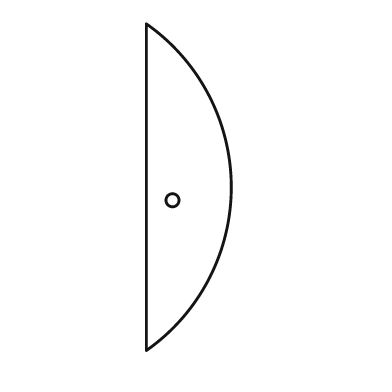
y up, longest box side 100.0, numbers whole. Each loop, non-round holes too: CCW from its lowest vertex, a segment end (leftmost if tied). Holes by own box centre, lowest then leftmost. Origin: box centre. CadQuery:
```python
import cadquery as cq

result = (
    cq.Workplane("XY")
    .moveTo(-13.0, -50.0)
    .threePointArc((13.0, 0.0), (-13.0, 50.0))
    .close()
    .moveTo(-5.0, -4.0)
    .circle(2.0)
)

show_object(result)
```